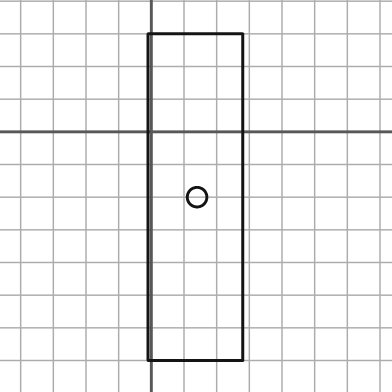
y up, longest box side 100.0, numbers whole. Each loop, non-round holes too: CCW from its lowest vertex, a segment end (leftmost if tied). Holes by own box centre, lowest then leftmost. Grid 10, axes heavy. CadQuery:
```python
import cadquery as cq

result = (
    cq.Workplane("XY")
    .moveTo(-1.0, -70.0)
    .lineTo(28.0, -70.0)
    .lineTo(28.0, 30.0)
    .lineTo(-1.0, 30.0)
    .close()
    .moveTo(14.0, -20.0)
    .circle(3.0)
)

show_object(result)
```